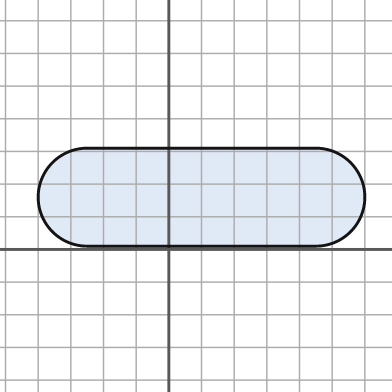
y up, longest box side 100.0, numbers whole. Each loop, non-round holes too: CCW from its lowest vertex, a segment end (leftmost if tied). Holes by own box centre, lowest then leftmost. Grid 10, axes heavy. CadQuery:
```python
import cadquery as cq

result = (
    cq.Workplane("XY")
    .moveTo(-25.0, 1.0)
    .lineTo(45.0, 1.0)
    .threePointArc((60.0, 16.0), (45.0, 31.0))
    .lineTo(-25.0, 31.0)
    .threePointArc((-40.0, 16.0), (-25.0, 1.0))
    .close()
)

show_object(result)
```